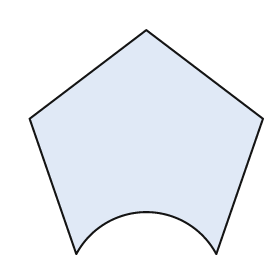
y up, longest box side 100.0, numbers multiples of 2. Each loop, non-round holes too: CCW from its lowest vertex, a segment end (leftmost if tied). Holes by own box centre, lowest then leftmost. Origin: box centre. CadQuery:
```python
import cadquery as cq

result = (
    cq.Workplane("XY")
    .moveTo(-30.0, -48.0)
    .threePointArc((0.0, -30.0), (30.0, -48.0))
    .lineTo(50.0, 10.0)
    .lineTo(0.0, 48.0)
    .lineTo(-50.0, 10.0)
    .close()
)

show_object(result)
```